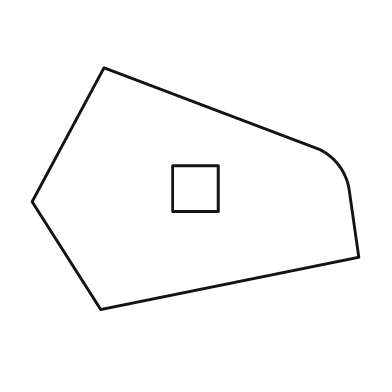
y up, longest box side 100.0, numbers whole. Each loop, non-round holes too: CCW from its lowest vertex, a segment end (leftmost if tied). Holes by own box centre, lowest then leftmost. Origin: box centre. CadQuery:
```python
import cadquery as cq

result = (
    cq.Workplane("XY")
    .moveTo(-29.0, -37.0)
    .lineTo(50.0, -21.0)
    .lineTo(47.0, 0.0)
    .threePointArc((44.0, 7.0), (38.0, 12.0))
    .lineTo(-28.0, 37.0)
    .lineTo(-50.0, -4.0)
    .close()
    .moveTo(-7.0, -7.0)
    .lineTo(7.0, -7.0)
    .lineTo(7.0, 7.0)
    .lineTo(-7.0, 7.0)
    .close()
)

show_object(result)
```